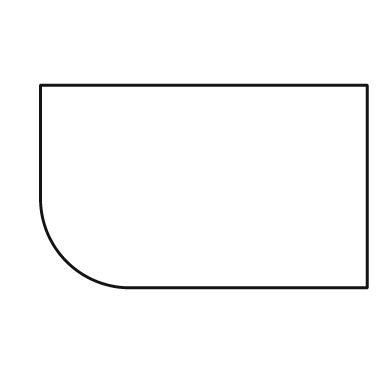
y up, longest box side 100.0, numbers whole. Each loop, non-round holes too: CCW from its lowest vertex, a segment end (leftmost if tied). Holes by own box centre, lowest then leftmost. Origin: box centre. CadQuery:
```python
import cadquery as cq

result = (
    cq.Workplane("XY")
    .moveTo(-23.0, -31.0)
    .lineTo(50.0, -31.0)
    .lineTo(50.0, 31.0)
    .lineTo(-50.0, 31.0)
    .lineTo(-50.0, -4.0)
    .threePointArc((-42.0, -23.0), (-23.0, -31.0))
    .close()
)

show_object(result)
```